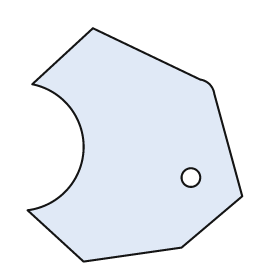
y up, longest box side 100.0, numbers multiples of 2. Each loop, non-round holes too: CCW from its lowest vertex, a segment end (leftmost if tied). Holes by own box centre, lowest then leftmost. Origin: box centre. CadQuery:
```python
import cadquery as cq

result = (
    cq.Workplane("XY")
    .moveTo(-22.0, -50.0)
    .lineTo(20.0, -44.0)
    .lineTo(46.0, -22.0)
    .lineTo(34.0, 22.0)
    .threePointArc((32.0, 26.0), (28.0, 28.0))
    .lineTo(-18.0, 50.0)
    .lineTo(-44.0, 26.0)
    .threePointArc((-22.0, -2.0), (-46.0, -28.0))
    .close()
    .moveTo(24.0, -14.0)
    .circle(4.0)
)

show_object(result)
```